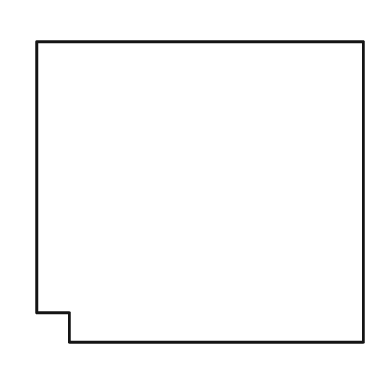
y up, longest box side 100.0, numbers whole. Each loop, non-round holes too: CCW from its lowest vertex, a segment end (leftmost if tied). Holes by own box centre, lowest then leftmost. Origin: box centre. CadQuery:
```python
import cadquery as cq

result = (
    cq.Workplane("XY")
    .moveTo(-40.0, -46.0)
    .lineTo(50.0, -46.0)
    .lineTo(50.0, 46.0)
    .lineTo(-50.0, 46.0)
    .lineTo(-50.0, -37.0)
    .lineTo(-40.0, -37.0)
    .close()
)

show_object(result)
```